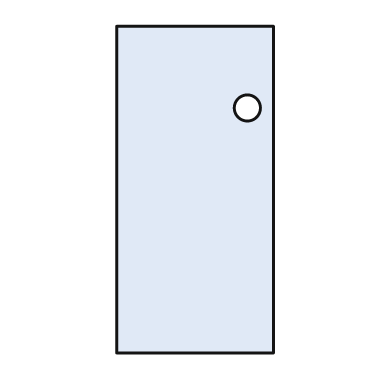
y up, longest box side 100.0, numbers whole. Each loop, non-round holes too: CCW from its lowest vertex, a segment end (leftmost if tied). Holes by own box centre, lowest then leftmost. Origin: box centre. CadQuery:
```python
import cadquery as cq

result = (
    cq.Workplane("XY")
    .moveTo(-24.0, -50.0)
    .lineTo(24.0, -50.0)
    .lineTo(24.0, 50.0)
    .lineTo(-24.0, 50.0)
    .close()
    .moveTo(16.0, 25.0)
    .circle(4.0)
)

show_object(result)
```